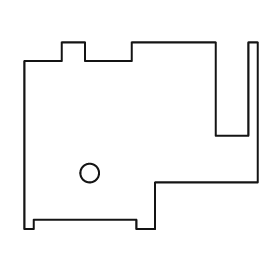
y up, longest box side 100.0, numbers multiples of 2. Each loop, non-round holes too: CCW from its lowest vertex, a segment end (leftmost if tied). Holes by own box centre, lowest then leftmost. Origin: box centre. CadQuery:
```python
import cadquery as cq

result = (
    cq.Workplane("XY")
    .moveTo(-50.0, -40.0)
    .lineTo(-46.0, -40.0)
    .lineTo(-46.0, -36.0)
    .lineTo(-2.0, -36.0)
    .lineTo(-2.0, -40.0)
    .lineTo(6.0, -40.0)
    .lineTo(6.0, -20.0)
    .lineTo(50.0, -20.0)
    .lineTo(50.0, 40.0)
    .lineTo(46.0, 40.0)
    .lineTo(46.0, 0.0)
    .lineTo(32.0, 0.0)
    .lineTo(32.0, 40.0)
    .lineTo(-4.0, 40.0)
    .lineTo(-4.0, 32.0)
    .lineTo(-24.0, 32.0)
    .lineTo(-24.0, 40.0)
    .lineTo(-34.0, 40.0)
    .lineTo(-34.0, 32.0)
    .lineTo(-50.0, 32.0)
    .close()
    .moveTo(-22.0, -16.0)
    .circle(4.0)
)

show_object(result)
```